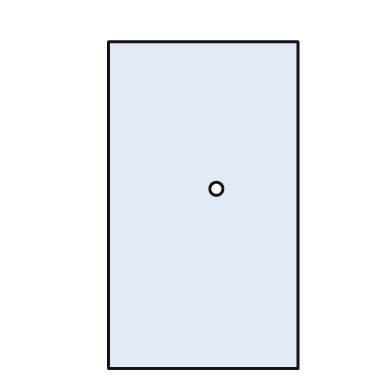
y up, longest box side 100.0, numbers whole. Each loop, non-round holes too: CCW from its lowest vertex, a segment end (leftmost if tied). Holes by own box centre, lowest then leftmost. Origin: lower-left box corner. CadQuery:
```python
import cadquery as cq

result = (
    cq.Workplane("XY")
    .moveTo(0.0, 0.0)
    .lineTo(58.0, 0.0)
    .lineTo(58.0, 100.0)
    .lineTo(0.0, 100.0)
    .close()
    .moveTo(33.0, 55.0)
    .circle(2.0)
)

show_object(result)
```